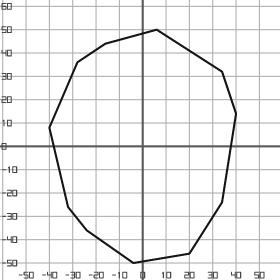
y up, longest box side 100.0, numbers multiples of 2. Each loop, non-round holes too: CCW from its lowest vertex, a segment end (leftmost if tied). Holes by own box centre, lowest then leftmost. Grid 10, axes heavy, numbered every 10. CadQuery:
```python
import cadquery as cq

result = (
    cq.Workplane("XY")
    .moveTo(-4.0, -50.0)
    .lineTo(20.0, -46.0)
    .lineTo(34.0, -24.0)
    .lineTo(40.0, 14.0)
    .lineTo(34.0, 32.0)
    .lineTo(6.0, 50.0)
    .lineTo(-16.0, 44.0)
    .lineTo(-28.0, 36.0)
    .lineTo(-40.0, 8.0)
    .lineTo(-32.0, -26.0)
    .lineTo(-24.0, -36.0)
    .close()
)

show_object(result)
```